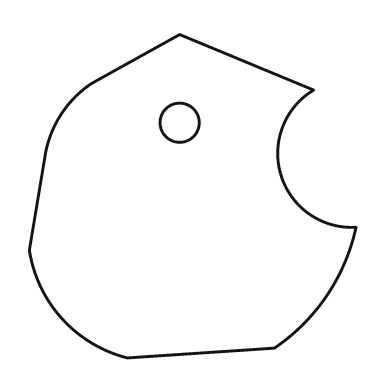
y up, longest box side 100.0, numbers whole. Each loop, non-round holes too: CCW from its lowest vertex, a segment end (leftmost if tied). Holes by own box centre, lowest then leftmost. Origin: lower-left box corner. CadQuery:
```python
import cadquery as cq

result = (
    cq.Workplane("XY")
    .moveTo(30.0, 0.0)
    .lineTo(75.0, 3.0)
    .threePointArc((91.0, 19.0), (100.0, 40.0))
    .threePointArc((77.0, 56.0), (87.0, 82.0))
    .lineTo(46.0, 99.0)
    .lineTo(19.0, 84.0)
    .threePointArc((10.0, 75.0), (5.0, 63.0))
    .lineTo(0.0, 33.0)
    .threePointArc((10.0, 12.0), (30.0, 0.0))
    .close()
    .moveTo(46.0, 72.0)
    .circle(6.0)
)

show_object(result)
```